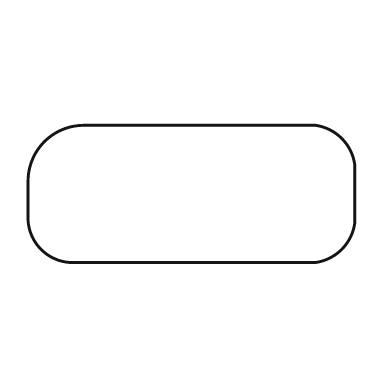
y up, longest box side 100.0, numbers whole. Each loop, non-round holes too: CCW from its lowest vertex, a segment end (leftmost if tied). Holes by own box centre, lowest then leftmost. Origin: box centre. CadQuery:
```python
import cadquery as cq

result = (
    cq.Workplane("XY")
    .moveTo(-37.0, -21.0)
    .lineTo(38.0, -21.0)
    .threePointArc((46.0, -17.0), (50.0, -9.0))
    .lineTo(50.0, 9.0)
    .threePointArc((46.0, 17.0), (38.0, 21.0))
    .lineTo(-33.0, 21.0)
    .threePointArc((-45.0, 16.0), (-50.0, 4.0))
    .lineTo(-50.0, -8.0)
    .threePointArc((-46.0, -17.0), (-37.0, -21.0))
    .close()
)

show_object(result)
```